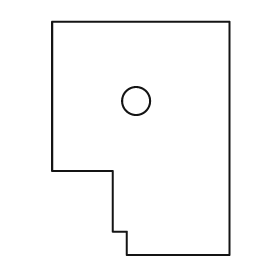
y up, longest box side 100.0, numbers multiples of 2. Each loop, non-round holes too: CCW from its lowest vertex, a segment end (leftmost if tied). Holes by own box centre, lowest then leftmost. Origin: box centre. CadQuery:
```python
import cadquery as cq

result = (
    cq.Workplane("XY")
    .moveTo(-6.0, -50.0)
    .lineTo(38.0, -50.0)
    .lineTo(38.0, 50.0)
    .lineTo(-38.0, 50.0)
    .lineTo(-38.0, -14.0)
    .lineTo(-12.0, -14.0)
    .lineTo(-12.0, -40.0)
    .lineTo(-6.0, -40.0)
    .close()
    .moveTo(-2.0, 16.0)
    .circle(6.0)
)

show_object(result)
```